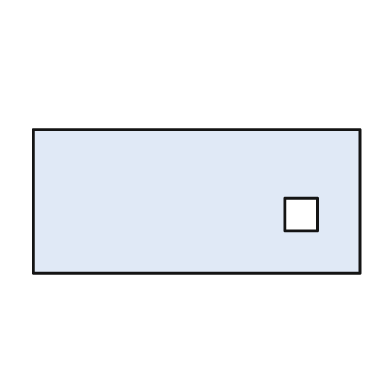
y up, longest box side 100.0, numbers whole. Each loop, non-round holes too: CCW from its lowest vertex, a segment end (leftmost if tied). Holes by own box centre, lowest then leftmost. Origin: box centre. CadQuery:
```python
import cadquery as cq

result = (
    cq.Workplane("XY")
    .moveTo(-50.0, -22.0)
    .lineTo(50.0, -22.0)
    .lineTo(50.0, 22.0)
    .lineTo(-50.0, 22.0)
    .close()
    .moveTo(27.0, -9.0)
    .lineTo(37.0, -9.0)
    .lineTo(37.0, 1.0)
    .lineTo(27.0, 1.0)
    .close()
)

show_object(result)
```